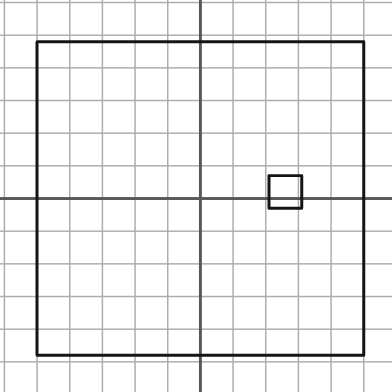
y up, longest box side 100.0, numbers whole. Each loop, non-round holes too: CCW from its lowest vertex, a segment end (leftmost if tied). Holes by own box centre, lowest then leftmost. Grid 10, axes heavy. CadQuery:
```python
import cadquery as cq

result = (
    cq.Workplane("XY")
    .moveTo(-50.0, -48.0)
    .lineTo(50.0, -48.0)
    .lineTo(50.0, 48.0)
    .lineTo(-50.0, 48.0)
    .close()
    .moveTo(21.0, -3.0)
    .lineTo(31.0, -3.0)
    .lineTo(31.0, 7.0)
    .lineTo(21.0, 7.0)
    .close()
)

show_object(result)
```